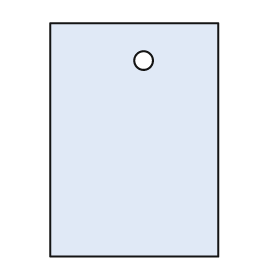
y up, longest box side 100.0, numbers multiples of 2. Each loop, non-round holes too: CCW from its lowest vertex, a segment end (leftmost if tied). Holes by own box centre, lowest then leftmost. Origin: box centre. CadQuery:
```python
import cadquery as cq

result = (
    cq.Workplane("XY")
    .moveTo(-36.0, -50.0)
    .lineTo(36.0, -50.0)
    .lineTo(36.0, 50.0)
    .lineTo(-36.0, 50.0)
    .close()
    .moveTo(4.0, 34.0)
    .circle(4.0)
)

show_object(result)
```